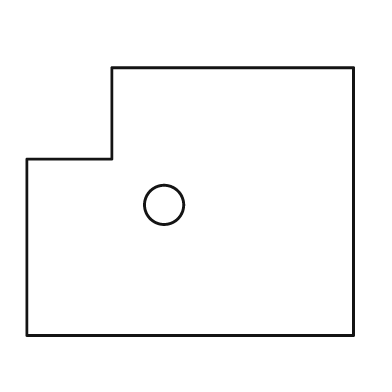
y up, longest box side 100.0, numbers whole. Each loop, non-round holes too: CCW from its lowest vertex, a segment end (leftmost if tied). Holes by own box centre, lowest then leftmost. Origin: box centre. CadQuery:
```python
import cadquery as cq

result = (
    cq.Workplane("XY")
    .moveTo(-50.0, -41.0)
    .lineTo(50.0, -41.0)
    .lineTo(50.0, 41.0)
    .lineTo(-24.0, 41.0)
    .lineTo(-24.0, 13.0)
    .lineTo(-50.0, 13.0)
    .close()
    .moveTo(-8.0, -1.0)
    .circle(6.0)
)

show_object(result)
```